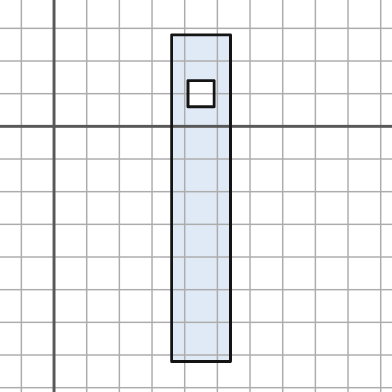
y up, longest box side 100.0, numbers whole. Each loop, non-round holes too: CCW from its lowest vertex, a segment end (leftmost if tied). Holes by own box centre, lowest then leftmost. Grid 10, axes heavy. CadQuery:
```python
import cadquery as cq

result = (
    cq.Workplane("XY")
    .moveTo(36.0, -72.0)
    .lineTo(54.0, -72.0)
    .lineTo(54.0, 28.0)
    .lineTo(36.0, 28.0)
    .close()
    .moveTo(41.0, 6.0)
    .lineTo(49.0, 6.0)
    .lineTo(49.0, 14.0)
    .lineTo(41.0, 14.0)
    .close()
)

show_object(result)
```